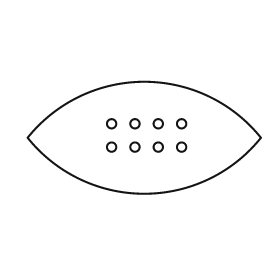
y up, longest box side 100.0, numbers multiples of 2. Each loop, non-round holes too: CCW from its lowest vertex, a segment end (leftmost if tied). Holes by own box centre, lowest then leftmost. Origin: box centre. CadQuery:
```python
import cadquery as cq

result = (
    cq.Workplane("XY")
    .moveTo(-50.0, 0.0)
    .threePointArc((0.0, -24.0), (50.0, 0.0))
    .threePointArc((0.0, 24.0), (-50.0, 0.0))
    .close()
    .moveTo(-14.0, -4.0)
    .circle(2.0)
    .moveTo(-4.0, -4.0)
    .circle(2.0)
    .moveTo(6.0, -4.0)
    .circle(2.0)
    .moveTo(16.0, -4.0)
    .circle(2.0)
    .moveTo(-14.0, 6.0)
    .circle(2.0)
    .moveTo(-4.0, 6.0)
    .circle(2.0)
    .moveTo(6.0, 6.0)
    .circle(2.0)
    .moveTo(16.0, 6.0)
    .circle(2.0)
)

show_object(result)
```